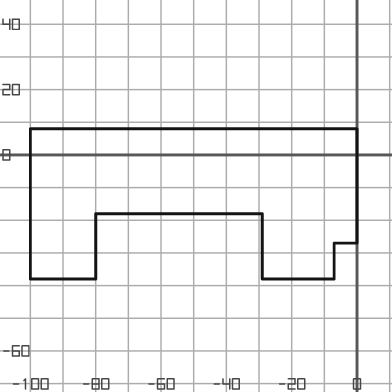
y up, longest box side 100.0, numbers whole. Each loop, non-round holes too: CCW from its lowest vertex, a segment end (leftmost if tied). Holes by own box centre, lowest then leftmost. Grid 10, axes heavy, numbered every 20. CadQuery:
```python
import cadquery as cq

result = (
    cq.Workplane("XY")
    .moveTo(-100.0, -38.0)
    .lineTo(-80.0, -38.0)
    .lineTo(-80.0, -18.0)
    .lineTo(-29.0, -18.0)
    .lineTo(-29.0, -38.0)
    .lineTo(-7.0, -38.0)
    .lineTo(-7.0, -27.0)
    .lineTo(0.0, -27.0)
    .lineTo(0.0, 8.0)
    .lineTo(-100.0, 8.0)
    .close()
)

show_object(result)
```